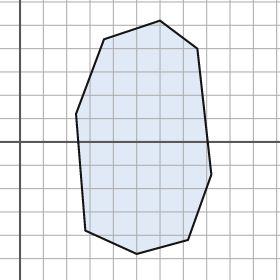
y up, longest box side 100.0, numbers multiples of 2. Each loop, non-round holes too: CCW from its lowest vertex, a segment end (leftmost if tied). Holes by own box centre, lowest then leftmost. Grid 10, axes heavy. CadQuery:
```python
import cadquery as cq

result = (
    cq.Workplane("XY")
    .moveTo(50.0, -48.0)
    .lineTo(72.0, -42.0)
    .lineTo(82.0, -14.0)
    .lineTo(76.0, 40.0)
    .lineTo(60.0, 52.0)
    .lineTo(36.0, 44.0)
    .lineTo(24.0, 12.0)
    .lineTo(28.0, -38.0)
    .close()
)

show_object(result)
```